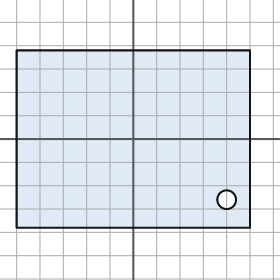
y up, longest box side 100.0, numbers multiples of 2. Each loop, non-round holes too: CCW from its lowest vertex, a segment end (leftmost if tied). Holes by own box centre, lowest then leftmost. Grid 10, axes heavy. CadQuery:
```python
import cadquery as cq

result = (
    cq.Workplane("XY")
    .moveTo(-50.0, -38.0)
    .lineTo(50.0, -38.0)
    .lineTo(50.0, 38.0)
    .lineTo(-50.0, 38.0)
    .close()
    .moveTo(40.0, -26.0)
    .circle(4.0)
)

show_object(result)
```